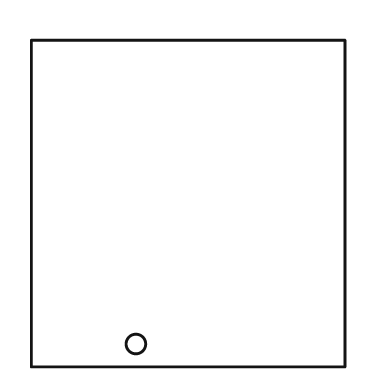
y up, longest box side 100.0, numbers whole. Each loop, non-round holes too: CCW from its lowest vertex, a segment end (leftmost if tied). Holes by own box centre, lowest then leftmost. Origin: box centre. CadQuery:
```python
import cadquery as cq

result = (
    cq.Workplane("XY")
    .moveTo(-48.0, -50.0)
    .lineTo(48.0, -50.0)
    .lineTo(48.0, 50.0)
    .lineTo(-48.0, 50.0)
    .close()
    .moveTo(-16.0, -43.0)
    .circle(3.0)
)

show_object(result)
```